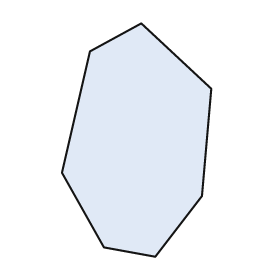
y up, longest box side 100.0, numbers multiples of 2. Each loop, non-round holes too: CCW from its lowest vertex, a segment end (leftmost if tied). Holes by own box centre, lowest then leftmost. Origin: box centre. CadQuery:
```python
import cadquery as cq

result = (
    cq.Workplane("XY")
    .moveTo(8.0, -50.0)
    .lineTo(28.0, -24.0)
    .lineTo(32.0, 22.0)
    .lineTo(2.0, 50.0)
    .lineTo(-20.0, 38.0)
    .lineTo(-32.0, -14.0)
    .lineTo(-14.0, -46.0)
    .close()
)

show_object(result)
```